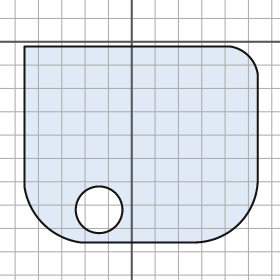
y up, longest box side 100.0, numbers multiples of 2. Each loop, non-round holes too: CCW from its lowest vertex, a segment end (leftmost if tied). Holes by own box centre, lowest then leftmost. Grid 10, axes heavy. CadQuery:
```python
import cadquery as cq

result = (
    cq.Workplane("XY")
    .moveTo(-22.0, -86.0)
    .lineTo(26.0, -86.0)
    .threePointArc((46.0, -78.0), (54.0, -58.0))
    .lineTo(54.0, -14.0)
    .threePointArc((50.0, -6.0), (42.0, -2.0))
    .lineTo(-46.0, -2.0)
    .lineTo(-46.0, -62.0)
    .threePointArc((-38.0, -78.0), (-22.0, -86.0))
    .close()
    .moveTo(-14.0, -72.0)
    .circle(10.0)
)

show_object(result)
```